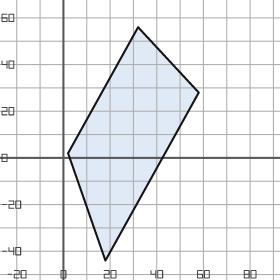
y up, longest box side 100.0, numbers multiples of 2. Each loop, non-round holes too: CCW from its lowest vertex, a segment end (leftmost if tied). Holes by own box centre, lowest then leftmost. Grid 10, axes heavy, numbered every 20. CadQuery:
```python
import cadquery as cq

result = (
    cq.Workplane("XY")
    .moveTo(18.0, -44.0)
    .lineTo(58.0, 28.0)
    .lineTo(32.0, 56.0)
    .lineTo(2.0, 2.0)
    .close()
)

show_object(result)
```